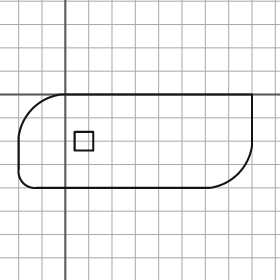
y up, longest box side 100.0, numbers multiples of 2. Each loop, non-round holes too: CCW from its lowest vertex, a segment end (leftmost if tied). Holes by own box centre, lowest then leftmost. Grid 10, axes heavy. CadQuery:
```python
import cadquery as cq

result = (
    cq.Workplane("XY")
    .moveTo(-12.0, -40.0)
    .lineTo(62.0, -40.0)
    .threePointArc((74.0, -34.0), (80.0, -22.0))
    .lineTo(80.0, 0.0)
    .lineTo(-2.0, 0.0)
    .threePointArc((-14.0, -6.0), (-20.0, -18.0))
    .lineTo(-20.0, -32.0)
    .threePointArc((-18.0, -38.0), (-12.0, -40.0))
    .close()
    .moveTo(4.0, -24.0)
    .lineTo(12.0, -24.0)
    .lineTo(12.0, -16.0)
    .lineTo(4.0, -16.0)
    .close()
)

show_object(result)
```